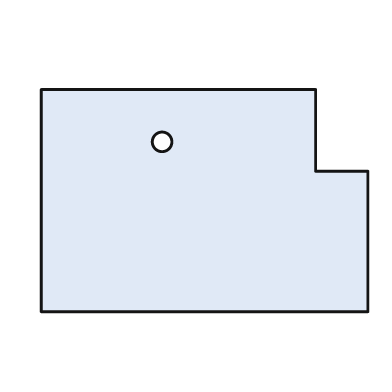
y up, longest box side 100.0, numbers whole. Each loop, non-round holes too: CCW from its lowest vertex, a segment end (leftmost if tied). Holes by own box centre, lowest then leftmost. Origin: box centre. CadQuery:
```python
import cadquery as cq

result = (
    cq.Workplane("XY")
    .moveTo(-50.0, -34.0)
    .lineTo(50.0, -34.0)
    .lineTo(50.0, 9.0)
    .lineTo(34.0, 9.0)
    .lineTo(34.0, 34.0)
    .lineTo(-50.0, 34.0)
    .close()
    .moveTo(-13.0, 18.0)
    .circle(3.0)
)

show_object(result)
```